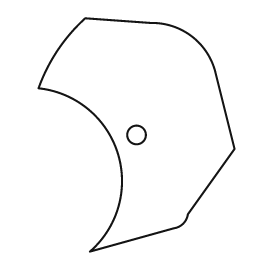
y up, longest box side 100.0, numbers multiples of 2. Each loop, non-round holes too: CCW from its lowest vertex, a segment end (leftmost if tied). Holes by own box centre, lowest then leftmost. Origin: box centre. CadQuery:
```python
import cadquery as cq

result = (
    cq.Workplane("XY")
    .moveTo(-20.0, -50.0)
    .lineTo(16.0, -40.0)
    .threePointArc((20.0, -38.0), (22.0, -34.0))
    .lineTo(42.0, -6.0)
    .lineTo(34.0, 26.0)
    .threePointArc((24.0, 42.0), (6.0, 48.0))
    .lineTo(-22.0, 50.0)
    .threePointArc((-34.0, 36.0), (-42.0, 20.0))
    .threePointArc((-8.0, -8.0), (-20.0, -50.0))
    .close()
    .moveTo(0.0, 0.0)
    .circle(4.0)
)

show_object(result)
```